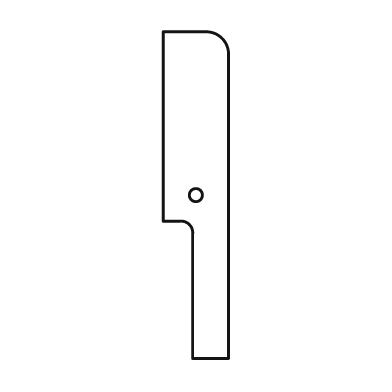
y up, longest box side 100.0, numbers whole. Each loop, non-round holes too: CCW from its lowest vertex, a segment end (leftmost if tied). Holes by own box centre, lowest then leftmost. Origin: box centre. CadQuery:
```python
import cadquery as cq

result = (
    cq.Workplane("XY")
    .moveTo(-1.0, -50.0)
    .lineTo(10.0, -50.0)
    .lineTo(10.0, 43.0)
    .threePointArc((8.0, 48.0), (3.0, 50.0))
    .lineTo(-10.0, 50.0)
    .lineTo(-10.0, -8.0)
    .lineTo(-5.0, -8.0)
    .threePointArc((-2.0, -9.0), (-1.0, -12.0))
    .close()
    .moveTo(0.0, 0.0)
    .circle(2.0)
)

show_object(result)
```